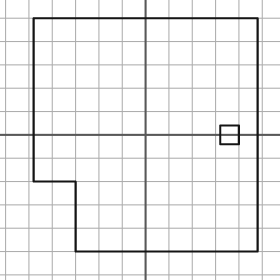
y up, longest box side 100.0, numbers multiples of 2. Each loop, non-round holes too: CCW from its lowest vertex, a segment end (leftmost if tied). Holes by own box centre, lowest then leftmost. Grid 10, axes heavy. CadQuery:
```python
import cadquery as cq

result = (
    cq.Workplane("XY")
    .moveTo(-30.0, -50.0)
    .lineTo(48.0, -50.0)
    .lineTo(48.0, 50.0)
    .lineTo(-48.0, 50.0)
    .lineTo(-48.0, -20.0)
    .lineTo(-30.0, -20.0)
    .close()
    .moveTo(32.0, -4.0)
    .lineTo(40.0, -4.0)
    .lineTo(40.0, 4.0)
    .lineTo(32.0, 4.0)
    .close()
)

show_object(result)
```